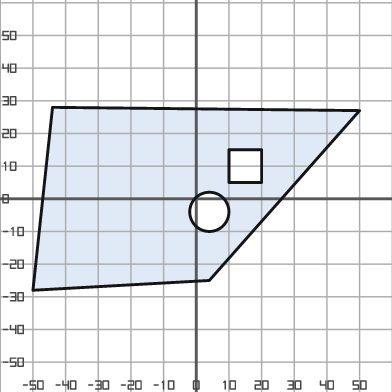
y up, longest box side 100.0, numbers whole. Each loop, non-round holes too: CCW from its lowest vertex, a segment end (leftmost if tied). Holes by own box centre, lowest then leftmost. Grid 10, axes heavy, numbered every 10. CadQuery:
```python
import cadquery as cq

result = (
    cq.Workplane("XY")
    .moveTo(-50.0, -28.0)
    .lineTo(4.0, -25.0)
    .lineTo(50.0, 27.0)
    .lineTo(-44.0, 28.0)
    .close()
    .moveTo(4.0, -4.0)
    .circle(6.0)
    .moveTo(10.0, 5.0)
    .lineTo(20.0, 5.0)
    .lineTo(20.0, 15.0)
    .lineTo(10.0, 15.0)
    .close()
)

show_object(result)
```